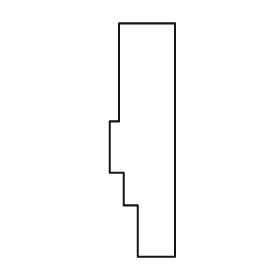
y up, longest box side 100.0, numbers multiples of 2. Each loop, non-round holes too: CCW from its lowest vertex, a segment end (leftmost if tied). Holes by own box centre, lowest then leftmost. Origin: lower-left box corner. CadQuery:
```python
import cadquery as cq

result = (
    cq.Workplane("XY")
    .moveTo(12.0, 0.0)
    .lineTo(28.0, 0.0)
    .lineTo(28.0, 100.0)
    .lineTo(4.0, 100.0)
    .lineTo(4.0, 58.0)
    .lineTo(0.0, 58.0)
    .lineTo(0.0, 36.0)
    .lineTo(6.0, 36.0)
    .lineTo(6.0, 22.0)
    .lineTo(12.0, 22.0)
    .close()
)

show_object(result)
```